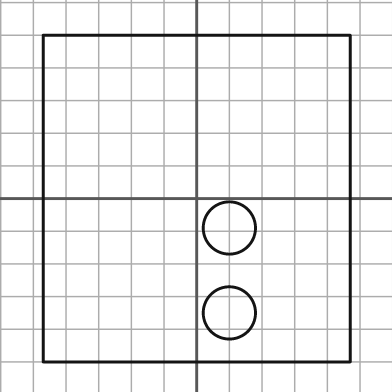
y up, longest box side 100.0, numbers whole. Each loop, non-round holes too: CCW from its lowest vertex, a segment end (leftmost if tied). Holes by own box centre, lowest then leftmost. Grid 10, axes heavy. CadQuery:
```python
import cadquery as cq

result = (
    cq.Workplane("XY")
    .moveTo(-47.0, -50.0)
    .lineTo(47.0, -50.0)
    .lineTo(47.0, 50.0)
    .lineTo(-47.0, 50.0)
    .close()
    .moveTo(10.0, -35.0)
    .circle(8.0)
    .moveTo(10.0, -9.0)
    .circle(8.0)
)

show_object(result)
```